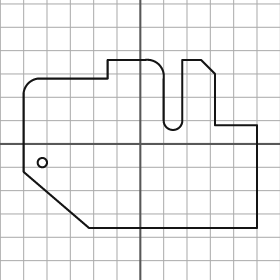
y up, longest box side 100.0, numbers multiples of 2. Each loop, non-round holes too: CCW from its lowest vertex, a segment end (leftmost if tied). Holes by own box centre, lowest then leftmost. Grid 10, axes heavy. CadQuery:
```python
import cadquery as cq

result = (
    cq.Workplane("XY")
    .moveTo(-22.0, -36.0)
    .lineTo(50.0, -36.0)
    .lineTo(50.0, 8.0)
    .lineTo(32.0, 8.0)
    .lineTo(32.0, 30.0)
    .lineTo(26.0, 36.0)
    .lineTo(18.0, 36.0)
    .lineTo(18.0, 10.0)
    .threePointArc((14.0, 6.0), (10.0, 10.0))
    .lineTo(10.0, 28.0)
    .threePointArc((8.0, 34.0), (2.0, 36.0))
    .lineTo(-14.0, 36.0)
    .lineTo(-14.0, 28.0)
    .lineTo(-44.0, 28.0)
    .threePointArc((-48.0, 26.0), (-50.0, 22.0))
    .lineTo(-50.0, -12.0)
    .close()
    .moveTo(-42.0, -8.0)
    .circle(2.0)
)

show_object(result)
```